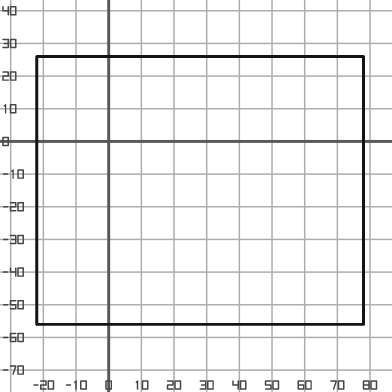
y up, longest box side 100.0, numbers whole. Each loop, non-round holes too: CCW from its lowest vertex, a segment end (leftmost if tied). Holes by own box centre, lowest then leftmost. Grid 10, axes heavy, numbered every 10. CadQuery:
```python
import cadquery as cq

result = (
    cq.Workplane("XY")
    .moveTo(-22.0, -56.0)
    .lineTo(78.0, -56.0)
    .lineTo(78.0, 26.0)
    .lineTo(-22.0, 26.0)
    .close()
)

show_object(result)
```